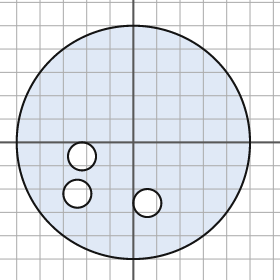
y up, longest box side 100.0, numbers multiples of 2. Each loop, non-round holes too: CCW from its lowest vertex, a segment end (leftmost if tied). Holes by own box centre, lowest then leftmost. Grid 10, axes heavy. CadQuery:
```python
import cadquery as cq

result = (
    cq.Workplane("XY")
    .moveTo(0.0, 0.0)
    .circle(50.0)
    .moveTo(6.0, -26.0)
    .circle(6.0)
    .moveTo(-24.0, -22.0)
    .circle(6.0)
    .moveTo(-22.0, -6.0)
    .circle(6.0)
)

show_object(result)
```